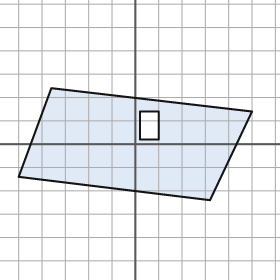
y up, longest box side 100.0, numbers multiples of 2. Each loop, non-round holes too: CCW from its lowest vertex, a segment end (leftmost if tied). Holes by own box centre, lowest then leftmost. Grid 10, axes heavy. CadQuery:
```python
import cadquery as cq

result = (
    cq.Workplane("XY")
    .moveTo(32.0, -24.0)
    .lineTo(50.0, 14.0)
    .lineTo(-36.0, 24.0)
    .lineTo(-50.0, -14.0)
    .close()
    .moveTo(2.0, 2.0)
    .lineTo(10.0, 2.0)
    .lineTo(10.0, 14.0)
    .lineTo(2.0, 14.0)
    .close()
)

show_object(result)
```